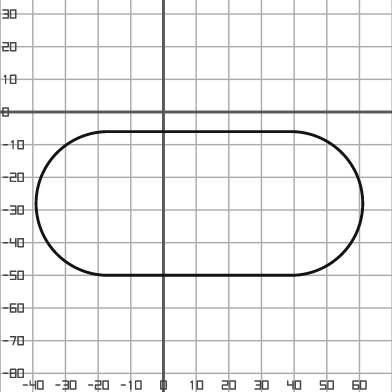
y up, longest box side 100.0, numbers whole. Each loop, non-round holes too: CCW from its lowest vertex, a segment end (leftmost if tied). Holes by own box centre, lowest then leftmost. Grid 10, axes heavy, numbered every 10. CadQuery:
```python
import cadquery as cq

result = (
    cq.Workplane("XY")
    .moveTo(-17.0, -50.0)
    .lineTo(39.0, -50.0)
    .threePointArc((61.0, -28.0), (39.0, -6.0))
    .lineTo(-17.0, -6.0)
    .threePointArc((-39.0, -28.0), (-17.0, -50.0))
    .close()
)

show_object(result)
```